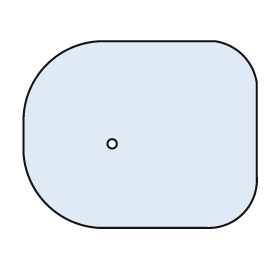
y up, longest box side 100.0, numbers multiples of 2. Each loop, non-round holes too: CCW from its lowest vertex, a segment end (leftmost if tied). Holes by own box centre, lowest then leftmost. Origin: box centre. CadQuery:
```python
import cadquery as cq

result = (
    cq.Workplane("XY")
    .moveTo(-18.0, -40.0)
    .lineTo(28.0, -40.0)
    .threePointArc((44.0, -34.0), (50.0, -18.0))
    .lineTo(50.0, 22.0)
    .threePointArc((44.0, 34.0), (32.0, 40.0))
    .lineTo(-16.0, 40.0)
    .threePointArc((-40.0, 30.0), (-50.0, 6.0))
    .lineTo(-50.0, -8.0)
    .threePointArc((-40.0, -30.0), (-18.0, -40.0))
    .close()
    .moveTo(-12.0, -4.0)
    .circle(2.0)
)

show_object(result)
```